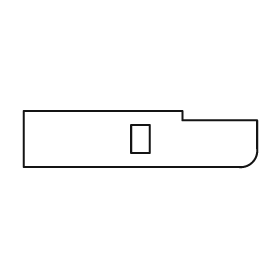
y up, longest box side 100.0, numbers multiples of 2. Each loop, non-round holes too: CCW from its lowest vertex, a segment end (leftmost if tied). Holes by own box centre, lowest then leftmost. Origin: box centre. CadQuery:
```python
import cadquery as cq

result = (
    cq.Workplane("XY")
    .moveTo(-50.0, -12.0)
    .lineTo(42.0, -12.0)
    .threePointArc((48.0, -10.0), (50.0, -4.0))
    .lineTo(50.0, 8.0)
    .lineTo(18.0, 8.0)
    .lineTo(18.0, 12.0)
    .lineTo(-50.0, 12.0)
    .close()
    .moveTo(-4.0, -6.0)
    .lineTo(4.0, -6.0)
    .lineTo(4.0, 6.0)
    .lineTo(-4.0, 6.0)
    .close()
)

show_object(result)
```